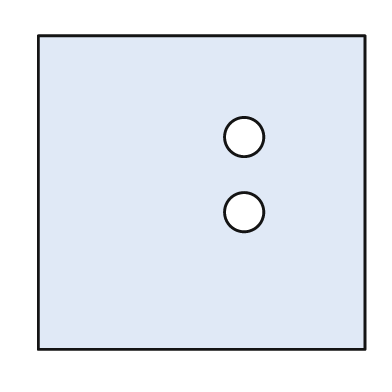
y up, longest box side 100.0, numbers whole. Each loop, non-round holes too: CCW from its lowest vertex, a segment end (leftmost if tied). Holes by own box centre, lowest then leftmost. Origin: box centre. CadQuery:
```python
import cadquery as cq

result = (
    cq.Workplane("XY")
    .moveTo(-50.0, -48.0)
    .lineTo(50.0, -48.0)
    .lineTo(50.0, 48.0)
    .lineTo(-50.0, 48.0)
    .close()
    .moveTo(13.0, -6.0)
    .circle(6.0)
    .moveTo(13.0, 17.0)
    .circle(6.0)
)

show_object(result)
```